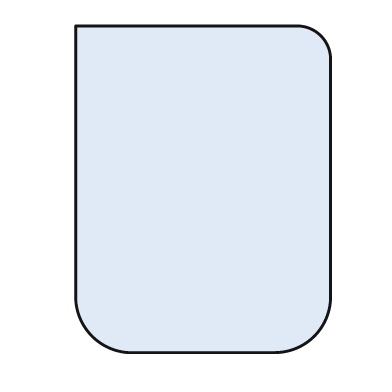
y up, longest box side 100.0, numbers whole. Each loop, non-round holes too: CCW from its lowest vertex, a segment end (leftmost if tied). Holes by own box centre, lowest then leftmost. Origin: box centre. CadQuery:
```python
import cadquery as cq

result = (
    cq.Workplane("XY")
    .moveTo(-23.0, -50.0)
    .lineTo(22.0, -50.0)
    .threePointArc((34.0, -45.0), (39.0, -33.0))
    .lineTo(39.0, 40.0)
    .threePointArc((36.0, 47.0), (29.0, 50.0))
    .lineTo(-39.0, 50.0)
    .lineTo(-39.0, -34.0)
    .threePointArc((-34.0, -45.0), (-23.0, -50.0))
    .close()
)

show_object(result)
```